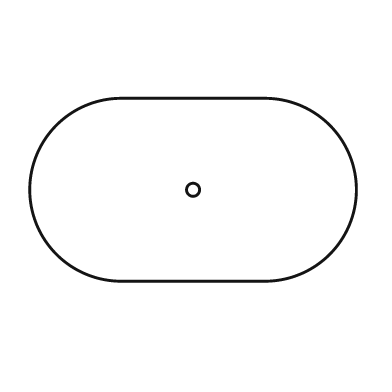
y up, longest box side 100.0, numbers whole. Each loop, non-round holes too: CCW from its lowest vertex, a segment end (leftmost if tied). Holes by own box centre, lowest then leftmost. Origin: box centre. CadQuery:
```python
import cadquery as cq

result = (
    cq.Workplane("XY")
    .moveTo(-22.0, -28.0)
    .lineTo(22.0, -28.0)
    .threePointArc((50.0, 0.0), (22.0, 28.0))
    .lineTo(-22.0, 28.0)
    .threePointArc((-50.0, 0.0), (-22.0, -28.0))
    .close()
    .moveTo(0.0, 0.0)
    .circle(2.0)
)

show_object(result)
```